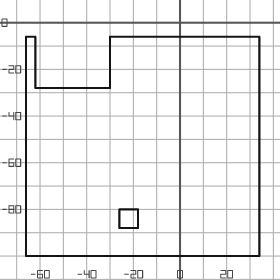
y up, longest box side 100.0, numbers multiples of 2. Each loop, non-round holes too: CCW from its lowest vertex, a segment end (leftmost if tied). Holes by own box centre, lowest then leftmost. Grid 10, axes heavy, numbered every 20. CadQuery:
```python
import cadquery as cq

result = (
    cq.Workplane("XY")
    .moveTo(-66.0, -100.0)
    .lineTo(34.0, -100.0)
    .lineTo(34.0, -6.0)
    .lineTo(-30.0, -6.0)
    .lineTo(-30.0, -28.0)
    .lineTo(-62.0, -28.0)
    .lineTo(-62.0, -6.0)
    .lineTo(-66.0, -6.0)
    .close()
    .moveTo(-26.0, -88.0)
    .lineTo(-18.0, -88.0)
    .lineTo(-18.0, -80.0)
    .lineTo(-26.0, -80.0)
    .close()
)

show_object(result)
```